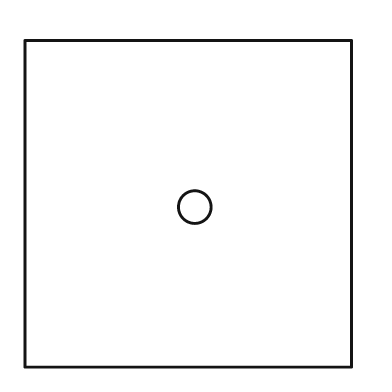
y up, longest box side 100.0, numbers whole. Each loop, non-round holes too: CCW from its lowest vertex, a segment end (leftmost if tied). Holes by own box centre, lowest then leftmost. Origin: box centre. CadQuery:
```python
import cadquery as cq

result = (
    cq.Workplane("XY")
    .moveTo(-50.0, -50.0)
    .lineTo(50.0, -50.0)
    .lineTo(50.0, 50.0)
    .lineTo(-50.0, 50.0)
    .close()
    .moveTo(2.0, -1.0)
    .circle(5.0)
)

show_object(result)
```